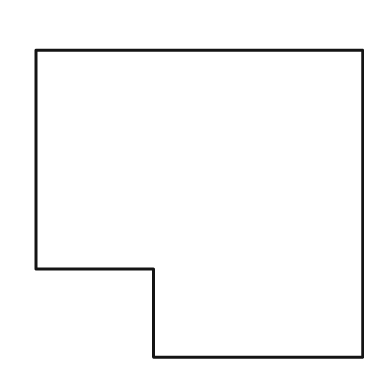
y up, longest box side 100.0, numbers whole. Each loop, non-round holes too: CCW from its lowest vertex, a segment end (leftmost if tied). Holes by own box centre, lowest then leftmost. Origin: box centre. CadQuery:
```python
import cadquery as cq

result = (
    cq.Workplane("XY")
    .moveTo(-14.0, -47.0)
    .lineTo(50.0, -47.0)
    .lineTo(50.0, 47.0)
    .lineTo(-50.0, 47.0)
    .lineTo(-50.0, -20.0)
    .lineTo(-14.0, -20.0)
    .close()
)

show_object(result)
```